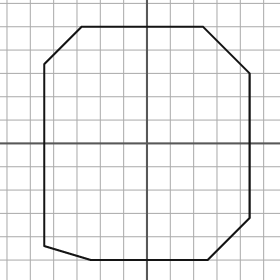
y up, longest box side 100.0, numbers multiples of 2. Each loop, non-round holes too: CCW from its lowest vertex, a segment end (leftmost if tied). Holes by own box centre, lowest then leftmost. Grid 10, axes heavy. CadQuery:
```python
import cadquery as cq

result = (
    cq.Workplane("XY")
    .moveTo(-24.0, -50.0)
    .lineTo(26.0, -50.0)
    .lineTo(44.0, -32.0)
    .lineTo(44.0, 30.0)
    .lineTo(24.0, 50.0)
    .lineTo(-28.0, 50.0)
    .lineTo(-44.0, 34.0)
    .lineTo(-44.0, -44.0)
    .close()
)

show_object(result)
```